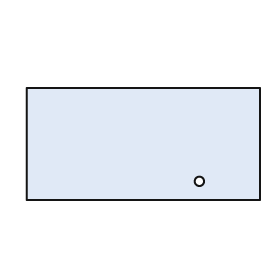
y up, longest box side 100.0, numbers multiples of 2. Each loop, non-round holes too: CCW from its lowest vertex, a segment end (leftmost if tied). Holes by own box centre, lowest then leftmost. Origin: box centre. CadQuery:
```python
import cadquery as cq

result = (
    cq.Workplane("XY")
    .moveTo(-50.0, -24.0)
    .lineTo(50.0, -24.0)
    .lineTo(50.0, 24.0)
    .lineTo(-50.0, 24.0)
    .close()
    .moveTo(24.0, -16.0)
    .circle(2.0)
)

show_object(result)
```